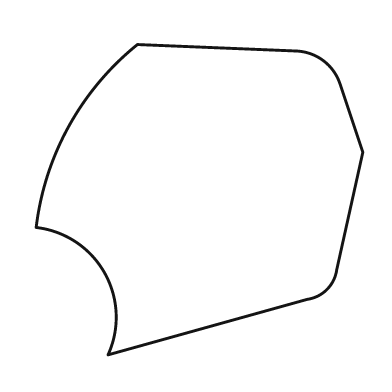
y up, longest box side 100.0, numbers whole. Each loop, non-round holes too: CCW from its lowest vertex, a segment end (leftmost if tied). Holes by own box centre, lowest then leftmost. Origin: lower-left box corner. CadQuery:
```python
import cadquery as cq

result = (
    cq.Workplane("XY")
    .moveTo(22.0, 0.0)
    .lineTo(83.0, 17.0)
    .threePointArc((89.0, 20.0), (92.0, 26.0))
    .lineTo(100.0, 62.0)
    .lineTo(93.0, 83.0)
    .threePointArc((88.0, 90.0), (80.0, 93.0))
    .lineTo(31.0, 95.0)
    .threePointArc((10.0, 70.0), (0.0, 39.0))
    .threePointArc((21.0, 25.0), (22.0, 0.0))
    .close()
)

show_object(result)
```